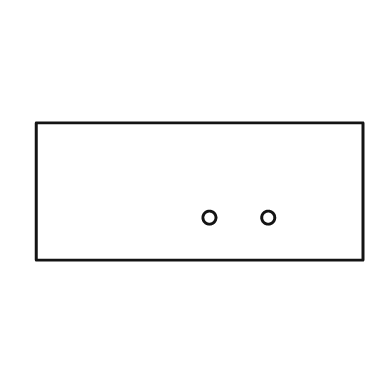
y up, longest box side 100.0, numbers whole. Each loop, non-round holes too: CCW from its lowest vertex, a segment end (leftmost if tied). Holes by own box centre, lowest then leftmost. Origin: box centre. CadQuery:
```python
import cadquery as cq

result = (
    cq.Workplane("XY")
    .moveTo(-50.0, -21.0)
    .lineTo(50.0, -21.0)
    .lineTo(50.0, 21.0)
    .lineTo(-50.0, 21.0)
    .close()
    .moveTo(3.0, -8.0)
    .circle(2.0)
    .moveTo(21.0, -8.0)
    .circle(2.0)
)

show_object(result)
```